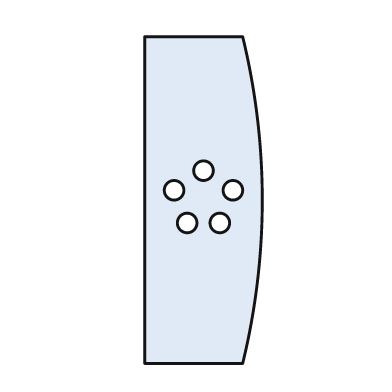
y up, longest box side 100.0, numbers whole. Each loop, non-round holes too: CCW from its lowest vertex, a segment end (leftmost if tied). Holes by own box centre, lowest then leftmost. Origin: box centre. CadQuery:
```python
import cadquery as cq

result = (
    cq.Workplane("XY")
    .moveTo(-18.0, -50.0)
    .lineTo(12.0, -50.0)
    .threePointArc((18.0, 0.0), (12.0, 50.0))
    .lineTo(-18.0, 50.0)
    .close()
    .moveTo(-5.0, -7.0)
    .circle(3.0)
    .moveTo(5.0, -7.0)
    .circle(3.0)
    .moveTo(-9.0, 3.0)
    .circle(3.0)
    .moveTo(9.0, 3.0)
    .circle(3.0)
    .moveTo(0.0, 9.0)
    .circle(3.0)
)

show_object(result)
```